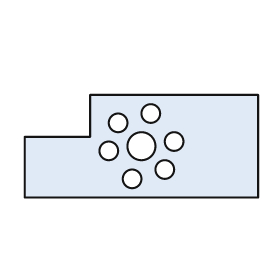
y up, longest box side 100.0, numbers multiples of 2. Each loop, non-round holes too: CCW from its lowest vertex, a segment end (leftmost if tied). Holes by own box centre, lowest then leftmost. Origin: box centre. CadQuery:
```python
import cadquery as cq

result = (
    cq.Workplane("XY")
    .moveTo(-50.0, -22.0)
    .lineTo(50.0, -22.0)
    .lineTo(50.0, 22.0)
    .lineTo(-22.0, 22.0)
    .lineTo(-22.0, 4.0)
    .lineTo(-50.0, 4.0)
    .close()
    .moveTo(-4.0, -14.0)
    .circle(4.0)
    .moveTo(10.0, -10.0)
    .circle(4.0)
    .moveTo(-14.0, -2.0)
    .circle(4.0)
    .moveTo(0.0, 0.0)
    .circle(6.0)
    .moveTo(14.0, 2.0)
    .circle(4.0)
    .moveTo(-10.0, 10.0)
    .circle(4.0)
    .moveTo(4.0, 14.0)
    .circle(4.0)
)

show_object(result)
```